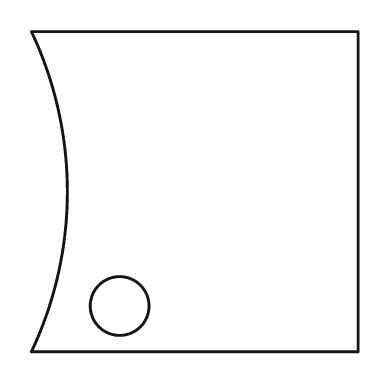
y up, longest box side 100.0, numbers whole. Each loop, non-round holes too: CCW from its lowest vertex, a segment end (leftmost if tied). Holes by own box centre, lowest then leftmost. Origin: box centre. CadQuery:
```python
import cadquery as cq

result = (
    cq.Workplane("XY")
    .moveTo(-50.0, -49.0)
    .lineTo(50.0, -49.0)
    .lineTo(50.0, 49.0)
    .lineTo(-50.0, 49.0)
    .threePointArc((-39.0, 0.0), (-50.0, -49.0))
    .close()
    .moveTo(-23.0, -35.0)
    .circle(9.0)
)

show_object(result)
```